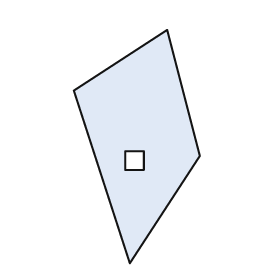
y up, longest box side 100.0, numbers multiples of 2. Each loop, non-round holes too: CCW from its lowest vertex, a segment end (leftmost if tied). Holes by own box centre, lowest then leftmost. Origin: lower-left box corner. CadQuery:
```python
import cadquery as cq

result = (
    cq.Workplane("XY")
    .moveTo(24.0, 0.0)
    .lineTo(54.0, 46.0)
    .lineTo(40.0, 100.0)
    .lineTo(0.0, 74.0)
    .close()
    .moveTo(22.0, 40.0)
    .lineTo(30.0, 40.0)
    .lineTo(30.0, 48.0)
    .lineTo(22.0, 48.0)
    .close()
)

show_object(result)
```